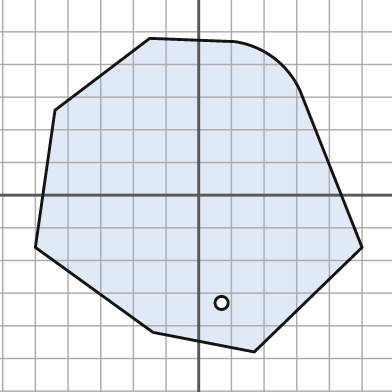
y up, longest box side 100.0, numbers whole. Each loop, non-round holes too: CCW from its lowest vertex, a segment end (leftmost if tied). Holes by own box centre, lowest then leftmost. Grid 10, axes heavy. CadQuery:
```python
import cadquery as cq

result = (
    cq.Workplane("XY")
    .moveTo(17.0, -48.0)
    .lineTo(50.0, -16.0)
    .lineTo(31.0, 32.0)
    .threePointArc((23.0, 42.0), (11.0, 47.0))
    .lineTo(-15.0, 48.0)
    .lineTo(-44.0, 26.0)
    .lineTo(-50.0, -16.0)
    .lineTo(-14.0, -42.0)
    .close()
    .moveTo(7.0, -33.0)
    .circle(2.0)
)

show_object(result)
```